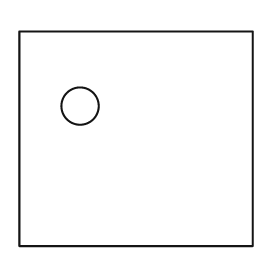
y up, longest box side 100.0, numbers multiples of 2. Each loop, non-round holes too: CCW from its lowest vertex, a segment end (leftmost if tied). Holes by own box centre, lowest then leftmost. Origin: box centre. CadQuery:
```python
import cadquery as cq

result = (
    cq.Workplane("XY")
    .moveTo(-50.0, -46.0)
    .lineTo(50.0, -46.0)
    .lineTo(50.0, 46.0)
    .lineTo(-50.0, 46.0)
    .close()
    .moveTo(-24.0, 14.0)
    .circle(8.0)
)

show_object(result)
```